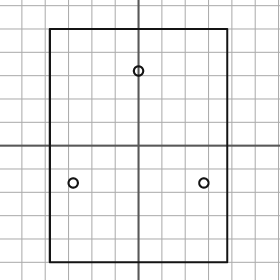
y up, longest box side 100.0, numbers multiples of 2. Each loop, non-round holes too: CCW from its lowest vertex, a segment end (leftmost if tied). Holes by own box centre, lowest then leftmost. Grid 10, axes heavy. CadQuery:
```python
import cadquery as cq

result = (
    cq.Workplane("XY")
    .moveTo(-38.0, -50.0)
    .lineTo(38.0, -50.0)
    .lineTo(38.0, 50.0)
    .lineTo(-38.0, 50.0)
    .close()
    .moveTo(-28.0, -16.0)
    .circle(2.0)
    .moveTo(28.0, -16.0)
    .circle(2.0)
    .moveTo(0.0, 32.0)
    .circle(2.0)
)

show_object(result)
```